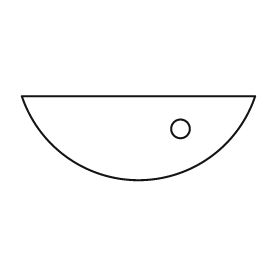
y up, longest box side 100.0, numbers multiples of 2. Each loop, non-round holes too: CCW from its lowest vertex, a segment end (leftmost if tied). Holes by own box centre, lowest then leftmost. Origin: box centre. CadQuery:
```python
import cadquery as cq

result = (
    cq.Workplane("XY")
    .moveTo(-50.0, 18.0)
    .threePointArc((0.0, -18.0), (50.0, 18.0))
    .close()
    .moveTo(18.0, 4.0)
    .circle(4.0)
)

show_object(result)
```